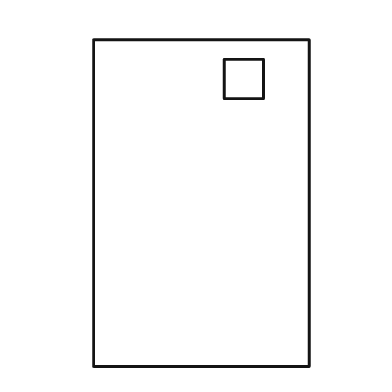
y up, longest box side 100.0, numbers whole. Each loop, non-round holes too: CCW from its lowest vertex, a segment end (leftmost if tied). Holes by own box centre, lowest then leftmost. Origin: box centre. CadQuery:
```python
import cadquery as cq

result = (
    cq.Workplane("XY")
    .moveTo(-33.0, -50.0)
    .lineTo(33.0, -50.0)
    .lineTo(33.0, 50.0)
    .lineTo(-33.0, 50.0)
    .close()
    .moveTo(7.0, 32.0)
    .lineTo(19.0, 32.0)
    .lineTo(19.0, 44.0)
    .lineTo(7.0, 44.0)
    .close()
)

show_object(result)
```